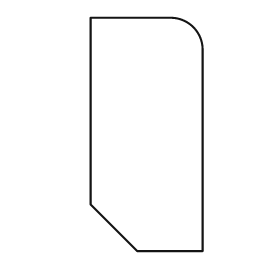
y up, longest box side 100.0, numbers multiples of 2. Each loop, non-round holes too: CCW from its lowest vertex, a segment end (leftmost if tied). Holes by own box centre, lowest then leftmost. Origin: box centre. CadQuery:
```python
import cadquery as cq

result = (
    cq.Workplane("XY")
    .moveTo(-4.0, -50.0)
    .lineTo(24.0, -50.0)
    .lineTo(24.0, 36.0)
    .threePointArc((20.0, 46.0), (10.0, 50.0))
    .lineTo(-24.0, 50.0)
    .lineTo(-24.0, -30.0)
    .close()
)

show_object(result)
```